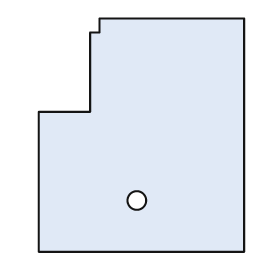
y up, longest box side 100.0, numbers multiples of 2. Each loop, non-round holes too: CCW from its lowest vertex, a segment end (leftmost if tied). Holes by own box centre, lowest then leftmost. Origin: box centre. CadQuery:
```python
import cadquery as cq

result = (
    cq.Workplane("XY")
    .moveTo(-44.0, -50.0)
    .lineTo(44.0, -50.0)
    .lineTo(44.0, 50.0)
    .lineTo(-18.0, 50.0)
    .lineTo(-18.0, 44.0)
    .lineTo(-22.0, 44.0)
    .lineTo(-22.0, 10.0)
    .lineTo(-44.0, 10.0)
    .close()
    .moveTo(-2.0, -28.0)
    .circle(4.0)
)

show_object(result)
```